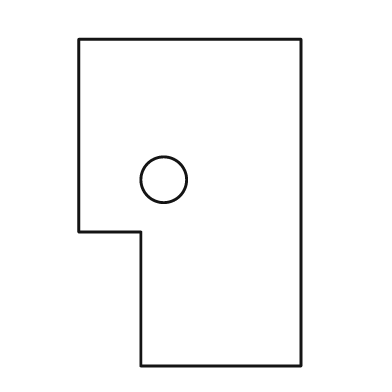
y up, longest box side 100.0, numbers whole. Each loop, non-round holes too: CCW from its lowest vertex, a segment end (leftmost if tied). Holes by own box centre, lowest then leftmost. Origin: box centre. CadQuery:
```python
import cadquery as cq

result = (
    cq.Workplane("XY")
    .moveTo(-15.0, -50.0)
    .lineTo(34.0, -50.0)
    .lineTo(34.0, 50.0)
    .lineTo(-34.0, 50.0)
    .lineTo(-34.0, -9.0)
    .lineTo(-15.0, -9.0)
    .close()
    .moveTo(-8.0, 7.0)
    .circle(7.0)
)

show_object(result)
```